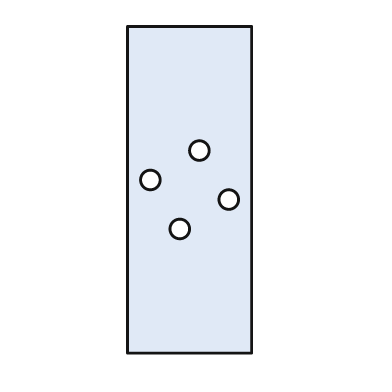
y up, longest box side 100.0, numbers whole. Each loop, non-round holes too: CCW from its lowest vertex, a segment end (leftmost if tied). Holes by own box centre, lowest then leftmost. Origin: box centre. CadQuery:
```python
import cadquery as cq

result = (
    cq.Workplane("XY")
    .moveTo(-19.0, -50.0)
    .lineTo(19.0, -50.0)
    .lineTo(19.0, 50.0)
    .lineTo(-19.0, 50.0)
    .close()
    .moveTo(-3.0, -12.0)
    .circle(3.0)
    .moveTo(12.0, -3.0)
    .circle(3.0)
    .moveTo(-12.0, 3.0)
    .circle(3.0)
    .moveTo(3.0, 12.0)
    .circle(3.0)
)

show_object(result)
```